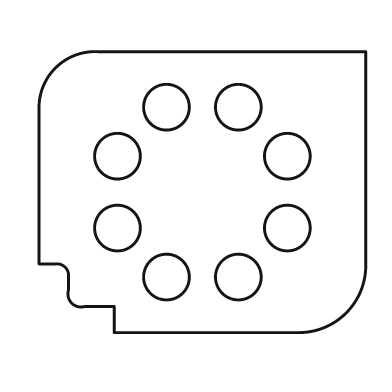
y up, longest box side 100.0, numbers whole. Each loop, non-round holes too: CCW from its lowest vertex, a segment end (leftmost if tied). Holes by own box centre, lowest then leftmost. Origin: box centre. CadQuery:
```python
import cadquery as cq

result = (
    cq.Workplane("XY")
    .moveTo(-27.0, -43.0)
    .lineTo(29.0, -43.0)
    .threePointArc((44.0, -37.0), (50.0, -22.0))
    .lineTo(50.0, 43.0)
    .lineTo(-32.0, 43.0)
    .threePointArc((-45.0, 38.0), (-50.0, 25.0))
    .lineTo(-50.0, -22.0)
    .lineTo(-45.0, -22.0)
    .threePointArc((-42.0, -23.0), (-41.0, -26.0))
    .lineTo(-41.0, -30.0)
    .threePointArc((-40.0, -34.0), (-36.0, -35.0))
    .lineTo(-27.0, -35.0)
    .close()
    .moveTo(-11.0, -26.0)
    .circle(7.0)
    .moveTo(11.0, -26.0)
    .circle(7.0)
    .moveTo(-26.0, -11.0)
    .circle(7.0)
    .moveTo(26.0, -11.0)
    .circle(7.0)
    .moveTo(-26.0, 11.0)
    .circle(7.0)
    .moveTo(26.0, 11.0)
    .circle(7.0)
    .moveTo(-11.0, 26.0)
    .circle(7.0)
    .moveTo(11.0, 26.0)
    .circle(7.0)
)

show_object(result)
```